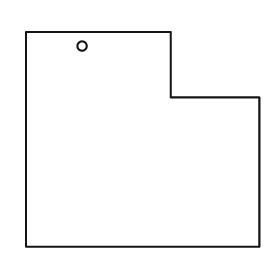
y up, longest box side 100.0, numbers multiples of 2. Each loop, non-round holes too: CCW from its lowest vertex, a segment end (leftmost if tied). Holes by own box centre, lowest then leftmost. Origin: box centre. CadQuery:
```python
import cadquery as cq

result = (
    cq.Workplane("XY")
    .moveTo(-50.0, -46.0)
    .lineTo(50.0, -46.0)
    .lineTo(50.0, 18.0)
    .lineTo(12.0, 18.0)
    .lineTo(12.0, 46.0)
    .lineTo(-50.0, 46.0)
    .close()
    .moveTo(-26.0, 40.0)
    .circle(2.0)
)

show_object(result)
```